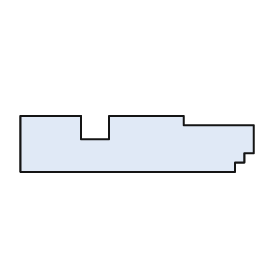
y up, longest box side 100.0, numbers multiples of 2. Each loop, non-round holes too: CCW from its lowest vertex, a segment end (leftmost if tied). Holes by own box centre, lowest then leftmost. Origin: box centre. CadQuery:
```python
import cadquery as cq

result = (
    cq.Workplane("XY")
    .moveTo(-50.0, -12.0)
    .lineTo(42.0, -12.0)
    .lineTo(42.0, -8.0)
    .lineTo(46.0, -8.0)
    .lineTo(46.0, -4.0)
    .lineTo(50.0, -4.0)
    .lineTo(50.0, 8.0)
    .lineTo(20.0, 8.0)
    .lineTo(20.0, 12.0)
    .lineTo(-12.0, 12.0)
    .lineTo(-12.0, 2.0)
    .lineTo(-24.0, 2.0)
    .lineTo(-24.0, 12.0)
    .lineTo(-50.0, 12.0)
    .close()
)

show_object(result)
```